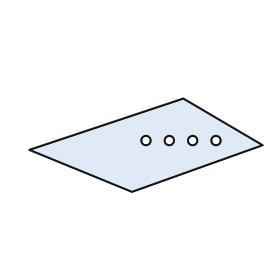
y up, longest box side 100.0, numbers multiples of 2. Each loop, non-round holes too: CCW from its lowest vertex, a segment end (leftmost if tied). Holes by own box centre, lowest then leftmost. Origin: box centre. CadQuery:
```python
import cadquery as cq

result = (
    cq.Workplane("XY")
    .moveTo(-6.0, -20.0)
    .lineTo(50.0, 0.0)
    .lineTo(16.0, 20.0)
    .lineTo(-50.0, -2.0)
    .close()
    .moveTo(0.0, 2.0)
    .circle(2.0)
    .moveTo(10.0, 2.0)
    .circle(2.0)
    .moveTo(20.0, 2.0)
    .circle(2.0)
    .moveTo(30.0, 2.0)
    .circle(2.0)
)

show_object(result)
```